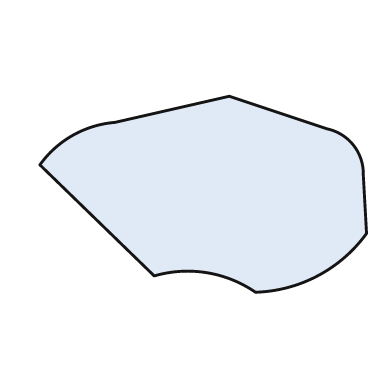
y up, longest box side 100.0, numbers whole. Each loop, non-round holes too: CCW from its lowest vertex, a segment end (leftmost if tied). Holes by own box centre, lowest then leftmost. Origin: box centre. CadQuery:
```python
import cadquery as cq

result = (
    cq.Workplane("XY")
    .moveTo(16.0, -30.0)
    .threePointArc((35.0, -25.0), (50.0, -12.0))
    .lineTo(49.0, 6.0)
    .threePointArc((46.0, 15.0), (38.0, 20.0))
    .lineTo(8.0, 30.0)
    .lineTo(-27.0, 22.0)
    .threePointArc((-40.0, 18.0), (-50.0, 9.0))
    .lineTo(-15.0, -25.0)
    .threePointArc((1.0, -24.0), (16.0, -30.0))
    .close()
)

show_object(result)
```